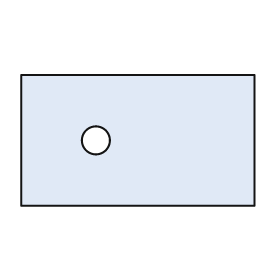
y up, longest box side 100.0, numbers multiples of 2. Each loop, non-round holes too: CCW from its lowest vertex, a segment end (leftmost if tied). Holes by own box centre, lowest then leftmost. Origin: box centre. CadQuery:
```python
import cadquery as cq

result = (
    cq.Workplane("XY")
    .moveTo(-50.0, -28.0)
    .lineTo(50.0, -28.0)
    .lineTo(50.0, 28.0)
    .lineTo(-50.0, 28.0)
    .close()
    .moveTo(-18.0, 0.0)
    .circle(6.0)
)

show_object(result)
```